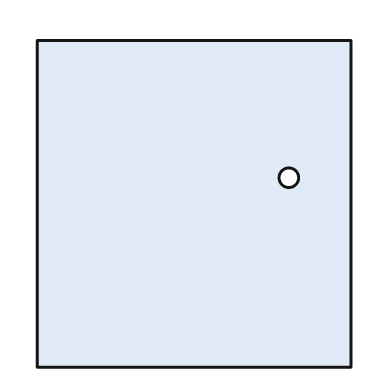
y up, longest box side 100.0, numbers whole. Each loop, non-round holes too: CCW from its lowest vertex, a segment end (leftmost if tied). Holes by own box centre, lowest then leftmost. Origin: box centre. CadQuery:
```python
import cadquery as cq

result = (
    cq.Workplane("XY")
    .moveTo(-48.0, -50.0)
    .lineTo(48.0, -50.0)
    .lineTo(48.0, 50.0)
    .lineTo(-48.0, 50.0)
    .close()
    .moveTo(29.0, 8.0)
    .circle(3.0)
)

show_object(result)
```